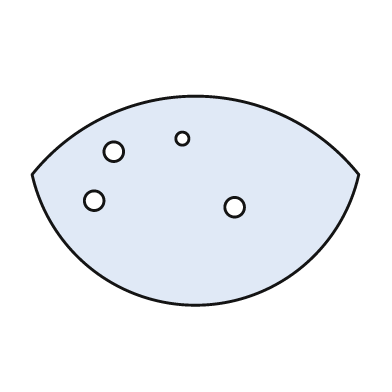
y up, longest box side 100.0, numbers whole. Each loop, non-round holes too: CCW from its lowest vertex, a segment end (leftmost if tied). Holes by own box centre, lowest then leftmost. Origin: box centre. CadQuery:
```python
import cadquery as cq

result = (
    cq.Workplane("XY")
    .moveTo(-50.0, 8.0)
    .threePointArc((0.0, -32.0), (50.0, 8.0))
    .threePointArc((0.0, 32.0), (-50.0, 8.0))
    .close()
    .moveTo(12.0, -2.0)
    .circle(3.0)
    .moveTo(-31.0, 0.0)
    .circle(3.0)
    .moveTo(-25.0, 15.0)
    .circle(3.0)
    .moveTo(-4.0, 19.0)
    .circle(2.0)
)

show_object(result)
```